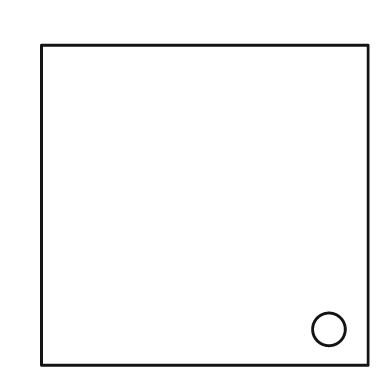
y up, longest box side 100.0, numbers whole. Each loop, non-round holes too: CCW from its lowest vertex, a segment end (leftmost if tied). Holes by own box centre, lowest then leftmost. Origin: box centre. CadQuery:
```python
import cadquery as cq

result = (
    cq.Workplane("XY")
    .moveTo(-50.0, -49.0)
    .lineTo(50.0, -49.0)
    .lineTo(50.0, 49.0)
    .lineTo(-50.0, 49.0)
    .close()
    .moveTo(38.0, -38.0)
    .circle(5.0)
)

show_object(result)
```